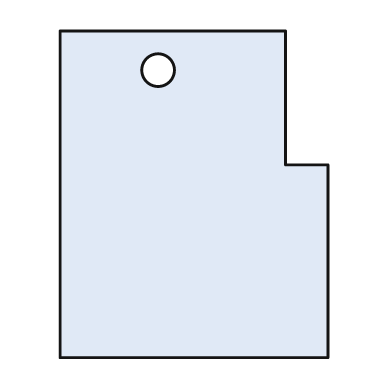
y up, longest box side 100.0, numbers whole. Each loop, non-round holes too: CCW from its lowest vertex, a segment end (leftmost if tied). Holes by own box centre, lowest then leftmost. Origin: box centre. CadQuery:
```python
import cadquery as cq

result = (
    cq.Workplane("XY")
    .moveTo(-41.0, -50.0)
    .lineTo(41.0, -50.0)
    .lineTo(41.0, 9.0)
    .lineTo(28.0, 9.0)
    .lineTo(28.0, 50.0)
    .lineTo(-41.0, 50.0)
    .close()
    .moveTo(-11.0, 38.0)
    .circle(5.0)
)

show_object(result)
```